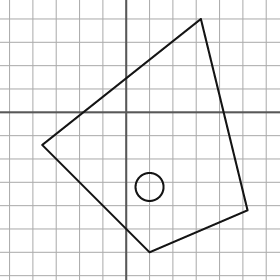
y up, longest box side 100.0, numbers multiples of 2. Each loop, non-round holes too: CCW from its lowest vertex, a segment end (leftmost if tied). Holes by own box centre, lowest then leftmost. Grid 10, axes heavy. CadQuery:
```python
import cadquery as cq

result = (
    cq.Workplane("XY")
    .moveTo(10.0, -60.0)
    .lineTo(52.0, -42.0)
    .lineTo(32.0, 40.0)
    .lineTo(-36.0, -14.0)
    .close()
    .moveTo(10.0, -32.0)
    .circle(6.0)
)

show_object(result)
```